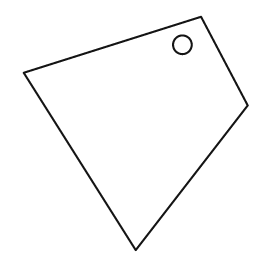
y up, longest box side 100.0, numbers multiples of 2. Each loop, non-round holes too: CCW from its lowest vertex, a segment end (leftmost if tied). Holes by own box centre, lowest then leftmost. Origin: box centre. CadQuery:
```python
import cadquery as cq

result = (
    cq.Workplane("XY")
    .moveTo(0.0, -50.0)
    .lineTo(48.0, 12.0)
    .lineTo(28.0, 50.0)
    .lineTo(-48.0, 26.0)
    .close()
    .moveTo(20.0, 38.0)
    .circle(4.0)
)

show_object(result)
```